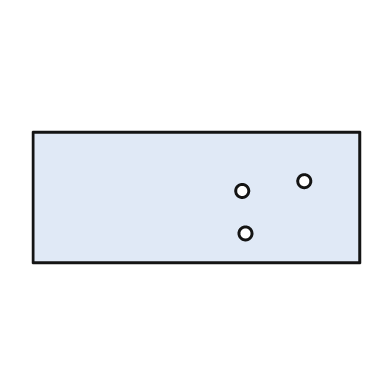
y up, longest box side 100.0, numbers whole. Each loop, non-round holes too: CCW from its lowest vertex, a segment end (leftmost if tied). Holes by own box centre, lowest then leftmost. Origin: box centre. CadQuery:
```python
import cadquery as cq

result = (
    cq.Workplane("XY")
    .moveTo(-50.0, -20.0)
    .lineTo(50.0, -20.0)
    .lineTo(50.0, 20.0)
    .lineTo(-50.0, 20.0)
    .close()
    .moveTo(15.0, -11.0)
    .circle(2.0)
    .moveTo(14.0, 2.0)
    .circle(2.0)
    .moveTo(33.0, 5.0)
    .circle(2.0)
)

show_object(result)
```